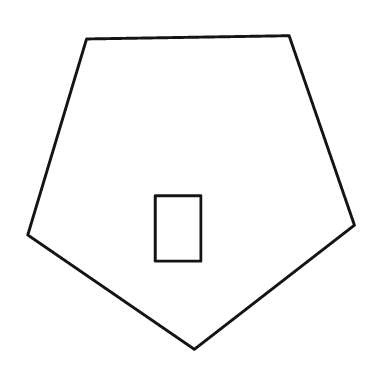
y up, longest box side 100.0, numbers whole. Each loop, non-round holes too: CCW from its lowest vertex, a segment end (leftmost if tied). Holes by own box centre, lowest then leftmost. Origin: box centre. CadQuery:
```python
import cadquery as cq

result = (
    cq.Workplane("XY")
    .moveTo(1.0, -48.0)
    .lineTo(50.0, -10.0)
    .lineTo(30.0, 48.0)
    .lineTo(-32.0, 47.0)
    .lineTo(-50.0, -13.0)
    .close()
    .moveTo(-11.0, -21.0)
    .lineTo(3.0, -21.0)
    .lineTo(3.0, -1.0)
    .lineTo(-11.0, -1.0)
    .close()
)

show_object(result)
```